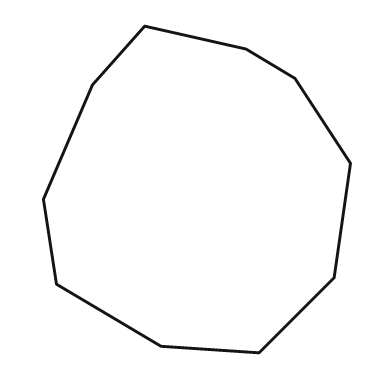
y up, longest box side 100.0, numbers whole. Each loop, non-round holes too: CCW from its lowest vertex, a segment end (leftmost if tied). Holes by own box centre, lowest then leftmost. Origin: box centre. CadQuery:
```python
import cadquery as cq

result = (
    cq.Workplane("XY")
    .moveTo(19.0, -50.0)
    .lineTo(42.0, -27.0)
    .lineTo(47.0, 8.0)
    .lineTo(30.0, 34.0)
    .lineTo(15.0, 43.0)
    .lineTo(-16.0, 50.0)
    .lineTo(-32.0, 32.0)
    .lineTo(-47.0, -3.0)
    .lineTo(-43.0, -29.0)
    .lineTo(-11.0, -48.0)
    .close()
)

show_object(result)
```